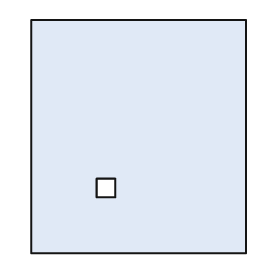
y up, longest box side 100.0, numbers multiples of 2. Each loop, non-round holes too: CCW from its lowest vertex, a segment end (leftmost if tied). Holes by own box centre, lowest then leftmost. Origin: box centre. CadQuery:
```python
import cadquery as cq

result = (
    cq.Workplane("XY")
    .moveTo(-46.0, -50.0)
    .lineTo(46.0, -50.0)
    .lineTo(46.0, 50.0)
    .lineTo(-46.0, 50.0)
    .close()
    .moveTo(-18.0, -26.0)
    .lineTo(-10.0, -26.0)
    .lineTo(-10.0, -18.0)
    .lineTo(-18.0, -18.0)
    .close()
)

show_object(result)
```